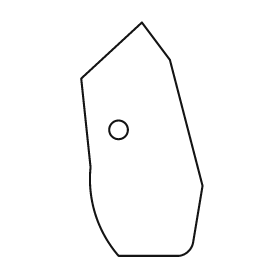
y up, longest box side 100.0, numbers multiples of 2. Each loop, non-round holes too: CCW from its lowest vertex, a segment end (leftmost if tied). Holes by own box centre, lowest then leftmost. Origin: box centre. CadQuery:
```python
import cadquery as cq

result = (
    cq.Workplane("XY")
    .moveTo(-10.0, -50.0)
    .lineTo(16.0, -50.0)
    .threePointArc((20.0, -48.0), (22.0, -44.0))
    .lineTo(26.0, -20.0)
    .lineTo(12.0, 34.0)
    .lineTo(0.0, 50.0)
    .lineTo(-26.0, 26.0)
    .lineTo(-22.0, -12.0)
    .threePointArc((-20.0, -32.0), (-10.0, -50.0))
    .close()
    .moveTo(-10.0, 4.0)
    .circle(4.0)
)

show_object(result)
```